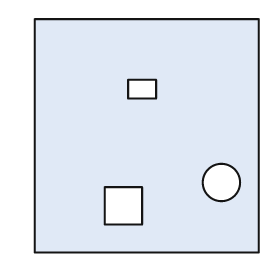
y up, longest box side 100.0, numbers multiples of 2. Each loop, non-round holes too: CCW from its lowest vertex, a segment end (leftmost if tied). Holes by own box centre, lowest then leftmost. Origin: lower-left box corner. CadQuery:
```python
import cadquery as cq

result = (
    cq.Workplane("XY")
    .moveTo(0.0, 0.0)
    .lineTo(96.0, 0.0)
    .lineTo(96.0, 100.0)
    .lineTo(0.0, 100.0)
    .close()
    .moveTo(30.0, 12.0)
    .lineTo(46.0, 12.0)
    .lineTo(46.0, 28.0)
    .lineTo(30.0, 28.0)
    .close()
    .moveTo(80.0, 30.0)
    .circle(8.0)
    .moveTo(40.0, 66.0)
    .lineTo(52.0, 66.0)
    .lineTo(52.0, 74.0)
    .lineTo(40.0, 74.0)
    .close()
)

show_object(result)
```